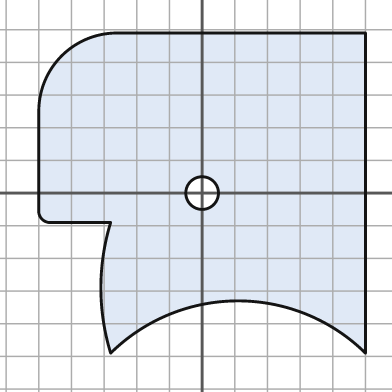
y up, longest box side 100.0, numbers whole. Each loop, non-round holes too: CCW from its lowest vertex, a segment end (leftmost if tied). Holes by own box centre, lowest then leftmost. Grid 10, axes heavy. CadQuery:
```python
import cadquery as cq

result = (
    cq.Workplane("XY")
    .moveTo(-28.0, -49.0)
    .threePointArc((11.0, -33.0), (50.0, -49.0))
    .lineTo(50.0, 49.0)
    .lineTo(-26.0, 49.0)
    .threePointArc((-43.0, 42.0), (-50.0, 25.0))
    .lineTo(-50.0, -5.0)
    .threePointArc((-49.0, -8.0), (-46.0, -9.0))
    .lineTo(-28.0, -9.0)
    .threePointArc((-31.0, -29.0), (-28.0, -49.0))
    .close()
    .moveTo(0.0, 0.0)
    .circle(5.0)
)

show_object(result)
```